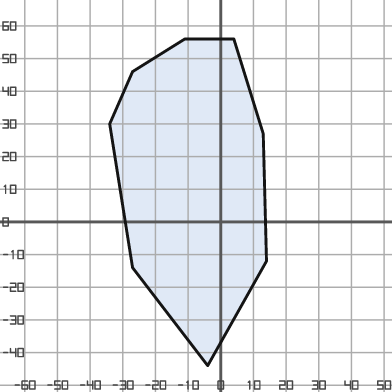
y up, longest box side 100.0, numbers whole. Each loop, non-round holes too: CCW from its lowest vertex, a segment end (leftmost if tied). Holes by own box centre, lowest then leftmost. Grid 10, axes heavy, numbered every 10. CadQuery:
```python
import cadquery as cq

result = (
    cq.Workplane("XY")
    .moveTo(-4.0, -44.0)
    .lineTo(14.0, -12.0)
    .lineTo(13.0, 27.0)
    .lineTo(4.0, 56.0)
    .lineTo(-11.0, 56.0)
    .lineTo(-27.0, 46.0)
    .lineTo(-34.0, 30.0)
    .lineTo(-27.0, -14.0)
    .close()
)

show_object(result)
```